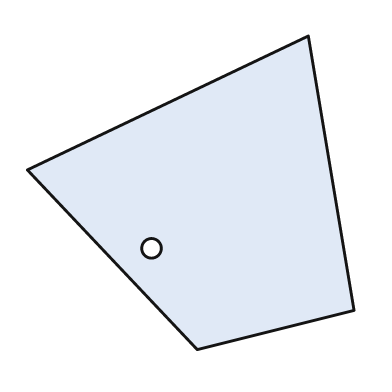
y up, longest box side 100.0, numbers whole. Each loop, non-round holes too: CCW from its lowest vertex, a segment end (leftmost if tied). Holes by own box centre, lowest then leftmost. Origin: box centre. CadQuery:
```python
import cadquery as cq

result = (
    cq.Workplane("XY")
    .moveTo(2.0, -48.0)
    .lineTo(50.0, -36.0)
    .lineTo(36.0, 48.0)
    .lineTo(-50.0, 7.0)
    .close()
    .moveTo(-12.0, -17.0)
    .circle(3.0)
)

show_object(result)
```